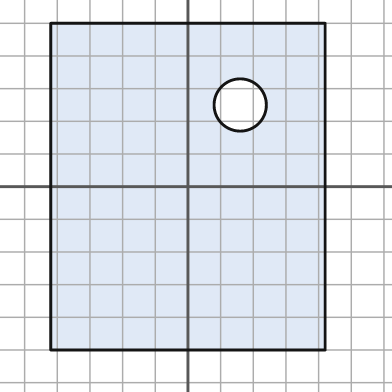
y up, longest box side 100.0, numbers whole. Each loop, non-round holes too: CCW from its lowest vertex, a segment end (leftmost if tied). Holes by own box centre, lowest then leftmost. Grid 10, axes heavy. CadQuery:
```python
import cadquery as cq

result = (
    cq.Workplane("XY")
    .moveTo(-42.0, -50.0)
    .lineTo(42.0, -50.0)
    .lineTo(42.0, 50.0)
    .lineTo(-42.0, 50.0)
    .close()
    .moveTo(16.0, 25.0)
    .circle(8.0)
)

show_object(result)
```